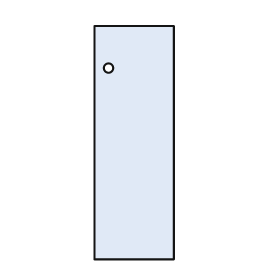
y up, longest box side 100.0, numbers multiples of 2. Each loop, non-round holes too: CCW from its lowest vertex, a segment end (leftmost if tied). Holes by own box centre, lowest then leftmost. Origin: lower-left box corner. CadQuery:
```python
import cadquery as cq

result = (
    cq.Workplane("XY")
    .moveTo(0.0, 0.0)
    .lineTo(34.0, 0.0)
    .lineTo(34.0, 100.0)
    .lineTo(0.0, 100.0)
    .close()
    .moveTo(6.0, 82.0)
    .circle(2.0)
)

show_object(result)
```